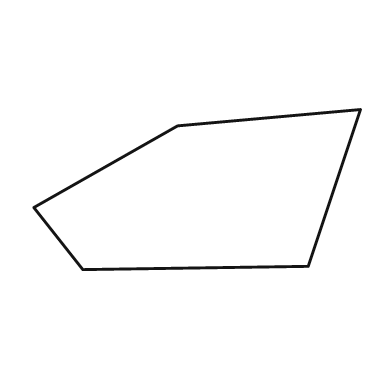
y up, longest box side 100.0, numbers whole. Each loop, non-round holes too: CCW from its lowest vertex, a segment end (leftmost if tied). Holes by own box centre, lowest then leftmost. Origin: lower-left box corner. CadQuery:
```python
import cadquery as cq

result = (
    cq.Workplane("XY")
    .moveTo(15.0, 0.0)
    .lineTo(84.0, 1.0)
    .lineTo(100.0, 49.0)
    .lineTo(44.0, 44.0)
    .lineTo(0.0, 19.0)
    .close()
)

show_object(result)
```